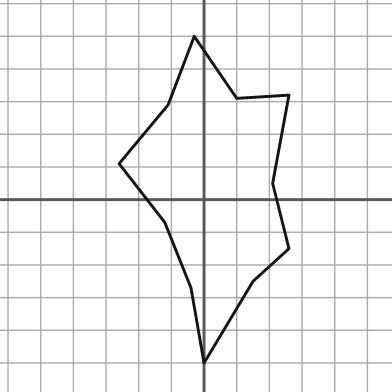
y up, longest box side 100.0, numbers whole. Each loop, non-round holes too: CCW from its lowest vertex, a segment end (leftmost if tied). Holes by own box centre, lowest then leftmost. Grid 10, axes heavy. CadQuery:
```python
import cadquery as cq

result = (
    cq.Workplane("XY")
    .moveTo(0.0, -50.0)
    .lineTo(15.0, -25.0)
    .lineTo(26.0, -15.0)
    .lineTo(21.0, 5.0)
    .lineTo(26.0, 32.0)
    .lineTo(10.0, 31.0)
    .lineTo(-3.0, 50.0)
    .lineTo(-11.0, 29.0)
    .lineTo(-26.0, 11.0)
    .lineTo(-12.0, -7.0)
    .lineTo(-4.0, -27.0)
    .close()
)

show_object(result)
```